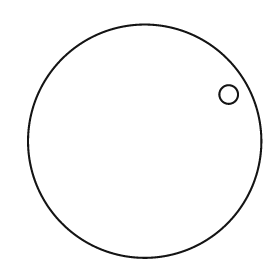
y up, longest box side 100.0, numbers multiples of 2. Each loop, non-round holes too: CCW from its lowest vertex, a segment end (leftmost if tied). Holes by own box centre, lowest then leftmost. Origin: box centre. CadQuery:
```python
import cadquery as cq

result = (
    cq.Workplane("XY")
    .moveTo(0.0, 0.0)
    .circle(50.0)
    .moveTo(36.0, 20.0)
    .circle(4.0)
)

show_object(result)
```